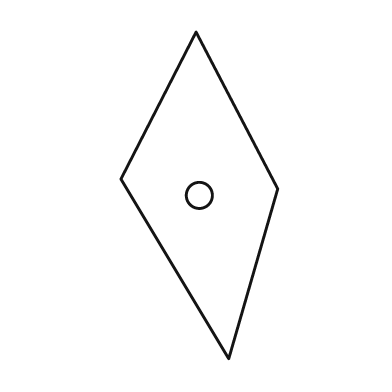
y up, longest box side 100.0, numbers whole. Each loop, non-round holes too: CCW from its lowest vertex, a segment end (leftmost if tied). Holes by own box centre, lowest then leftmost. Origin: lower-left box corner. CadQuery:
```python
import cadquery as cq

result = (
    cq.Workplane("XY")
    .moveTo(33.0, 0.0)
    .lineTo(48.0, 52.0)
    .lineTo(23.0, 100.0)
    .lineTo(0.0, 55.0)
    .close()
    .moveTo(24.0, 50.0)
    .circle(4.0)
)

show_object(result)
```